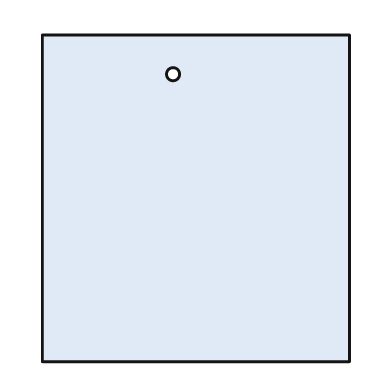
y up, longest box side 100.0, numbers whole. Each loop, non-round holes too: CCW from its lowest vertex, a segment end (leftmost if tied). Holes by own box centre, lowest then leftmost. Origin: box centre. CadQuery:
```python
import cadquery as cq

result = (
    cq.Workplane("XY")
    .moveTo(-47.0, -50.0)
    .lineTo(47.0, -50.0)
    .lineTo(47.0, 50.0)
    .lineTo(-47.0, 50.0)
    .close()
    .moveTo(-7.0, 38.0)
    .circle(2.0)
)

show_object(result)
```